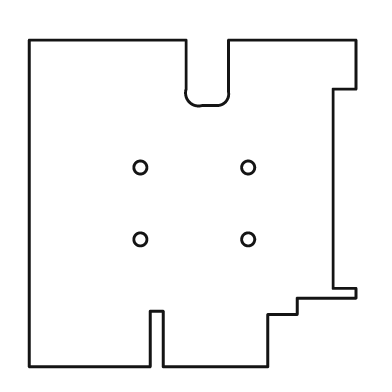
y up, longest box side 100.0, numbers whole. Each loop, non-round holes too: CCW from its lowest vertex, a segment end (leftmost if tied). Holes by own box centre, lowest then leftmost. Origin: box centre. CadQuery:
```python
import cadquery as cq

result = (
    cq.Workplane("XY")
    .moveTo(-50.0, -50.0)
    .lineTo(-13.0, -50.0)
    .lineTo(-13.0, -33.0)
    .lineTo(-9.0, -33.0)
    .lineTo(-9.0, -50.0)
    .lineTo(23.0, -50.0)
    .lineTo(23.0, -34.0)
    .lineTo(32.0, -34.0)
    .lineTo(32.0, -29.0)
    .lineTo(50.0, -29.0)
    .lineTo(50.0, -26.0)
    .lineTo(43.0, -26.0)
    .lineTo(43.0, 35.0)
    .lineTo(50.0, 35.0)
    .lineTo(50.0, 50.0)
    .lineTo(11.0, 50.0)
    .lineTo(11.0, 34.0)
    .threePointArc((10.0, 31.0), (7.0, 30.0))
    .lineTo(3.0, 30.0)
    .threePointArc((-1.0, 31.0), (-2.0, 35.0))
    .lineTo(-2.0, 50.0)
    .lineTo(-50.0, 50.0)
    .close()
    .moveTo(-16.0, -11.0)
    .circle(2.0)
    .moveTo(17.0, -11.0)
    .circle(2.0)
    .moveTo(-16.0, 11.0)
    .circle(2.0)
    .moveTo(17.0, 11.0)
    .circle(2.0)
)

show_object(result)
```